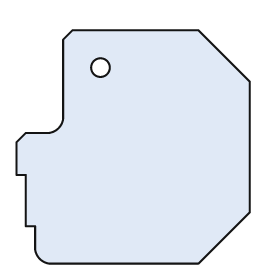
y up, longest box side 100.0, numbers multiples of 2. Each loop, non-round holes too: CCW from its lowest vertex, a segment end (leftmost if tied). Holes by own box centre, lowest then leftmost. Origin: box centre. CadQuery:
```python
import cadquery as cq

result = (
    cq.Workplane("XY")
    .moveTo(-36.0, -50.0)
    .lineTo(28.0, -50.0)
    .lineTo(50.0, -28.0)
    .lineTo(50.0, 28.0)
    .lineTo(28.0, 50.0)
    .lineTo(-26.0, 50.0)
    .lineTo(-30.0, 46.0)
    .lineTo(-30.0, 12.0)
    .threePointArc((-32.0, 8.0), (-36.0, 6.0))
    .lineTo(-46.0, 6.0)
    .lineTo(-50.0, 2.0)
    .lineTo(-50.0, -12.0)
    .lineTo(-46.0, -12.0)
    .lineTo(-46.0, -34.0)
    .lineTo(-42.0, -34.0)
    .lineTo(-42.0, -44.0)
    .threePointArc((-40.0, -48.0), (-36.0, -50.0))
    .close()
    .moveTo(-14.0, 34.0)
    .circle(4.0)
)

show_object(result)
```